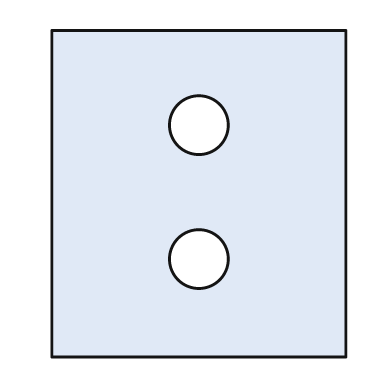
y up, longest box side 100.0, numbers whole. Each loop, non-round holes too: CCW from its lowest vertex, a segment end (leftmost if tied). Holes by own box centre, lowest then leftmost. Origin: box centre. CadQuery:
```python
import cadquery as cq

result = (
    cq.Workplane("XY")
    .moveTo(-45.0, -50.0)
    .lineTo(45.0, -50.0)
    .lineTo(45.0, 50.0)
    .lineTo(-45.0, 50.0)
    .close()
    .moveTo(0.0, -20.0)
    .circle(9.0)
    .moveTo(0.0, 21.0)
    .circle(9.0)
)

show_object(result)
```